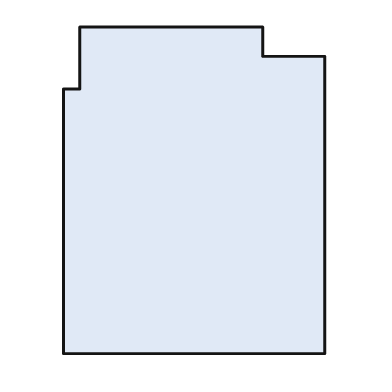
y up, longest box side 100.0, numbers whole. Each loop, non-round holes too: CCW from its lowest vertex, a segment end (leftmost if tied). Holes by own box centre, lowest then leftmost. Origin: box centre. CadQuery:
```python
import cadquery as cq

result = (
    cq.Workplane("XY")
    .moveTo(-40.0, -50.0)
    .lineTo(40.0, -50.0)
    .lineTo(40.0, 41.0)
    .lineTo(21.0, 41.0)
    .lineTo(21.0, 50.0)
    .lineTo(-35.0, 50.0)
    .lineTo(-35.0, 31.0)
    .lineTo(-40.0, 31.0)
    .close()
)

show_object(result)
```